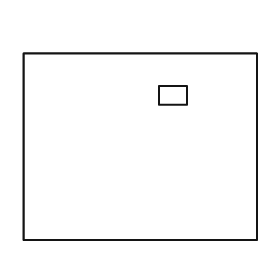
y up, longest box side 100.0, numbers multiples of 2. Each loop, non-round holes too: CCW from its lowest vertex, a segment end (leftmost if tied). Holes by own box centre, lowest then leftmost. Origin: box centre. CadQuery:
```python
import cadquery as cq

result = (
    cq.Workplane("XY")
    .moveTo(-50.0, -40.0)
    .lineTo(50.0, -40.0)
    .lineTo(50.0, 40.0)
    .lineTo(-50.0, 40.0)
    .close()
    .moveTo(8.0, 18.0)
    .lineTo(20.0, 18.0)
    .lineTo(20.0, 26.0)
    .lineTo(8.0, 26.0)
    .close()
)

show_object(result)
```